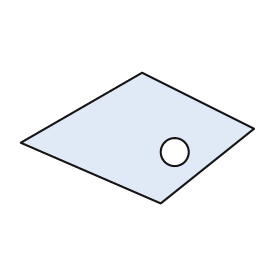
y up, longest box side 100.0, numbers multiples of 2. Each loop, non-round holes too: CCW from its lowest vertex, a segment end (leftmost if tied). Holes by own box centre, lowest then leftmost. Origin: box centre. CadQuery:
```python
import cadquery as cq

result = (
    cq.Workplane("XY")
    .moveTo(10.0, -28.0)
    .lineTo(50.0, 4.0)
    .lineTo(2.0, 28.0)
    .lineTo(-50.0, -2.0)
    .close()
    .moveTo(16.0, -6.0)
    .circle(6.0)
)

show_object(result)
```